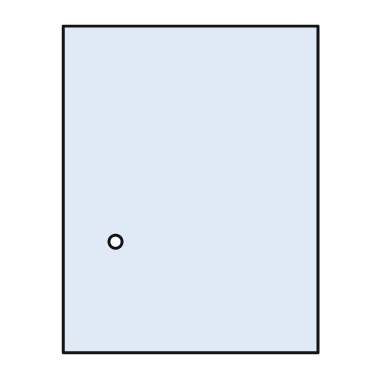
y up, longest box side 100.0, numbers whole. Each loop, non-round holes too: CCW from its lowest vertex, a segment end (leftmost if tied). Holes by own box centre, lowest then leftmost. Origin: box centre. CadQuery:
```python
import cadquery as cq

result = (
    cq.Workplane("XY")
    .moveTo(-39.0, -50.0)
    .lineTo(39.0, -50.0)
    .lineTo(39.0, 50.0)
    .lineTo(-39.0, 50.0)
    .close()
    .moveTo(-23.0, -16.0)
    .circle(2.0)
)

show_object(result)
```